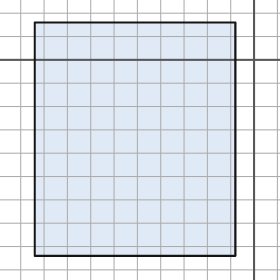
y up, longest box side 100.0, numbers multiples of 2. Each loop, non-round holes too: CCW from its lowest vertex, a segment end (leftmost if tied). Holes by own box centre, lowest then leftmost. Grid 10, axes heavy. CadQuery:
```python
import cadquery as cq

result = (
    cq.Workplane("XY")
    .moveTo(-94.0, -84.0)
    .lineTo(-8.0, -84.0)
    .lineTo(-8.0, 16.0)
    .lineTo(-94.0, 16.0)
    .close()
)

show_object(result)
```